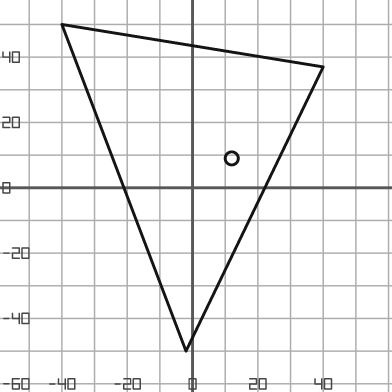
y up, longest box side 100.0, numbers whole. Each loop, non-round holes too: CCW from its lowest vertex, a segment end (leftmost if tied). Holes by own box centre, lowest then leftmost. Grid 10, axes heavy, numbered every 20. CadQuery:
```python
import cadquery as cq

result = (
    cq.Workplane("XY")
    .moveTo(-2.0, -50.0)
    .lineTo(40.0, 37.0)
    .lineTo(-40.0, 50.0)
    .close()
    .moveTo(12.0, 9.0)
    .circle(2.0)
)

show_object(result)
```